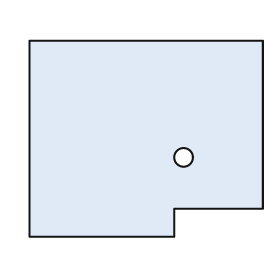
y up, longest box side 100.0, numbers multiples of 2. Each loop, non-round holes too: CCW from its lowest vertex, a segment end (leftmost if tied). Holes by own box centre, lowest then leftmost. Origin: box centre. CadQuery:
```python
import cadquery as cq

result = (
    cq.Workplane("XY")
    .moveTo(-50.0, -42.0)
    .lineTo(12.0, -42.0)
    .lineTo(12.0, -30.0)
    .lineTo(50.0, -30.0)
    .lineTo(50.0, 42.0)
    .lineTo(-50.0, 42.0)
    .close()
    .moveTo(16.0, -8.0)
    .circle(4.0)
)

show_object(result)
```